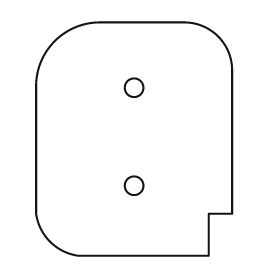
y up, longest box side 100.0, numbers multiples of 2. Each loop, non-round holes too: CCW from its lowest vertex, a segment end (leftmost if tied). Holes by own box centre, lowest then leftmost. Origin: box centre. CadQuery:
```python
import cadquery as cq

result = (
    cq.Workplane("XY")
    .moveTo(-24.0, -50.0)
    .lineTo(32.0, -50.0)
    .lineTo(32.0, -32.0)
    .lineTo(42.0, -32.0)
    .lineTo(42.0, 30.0)
    .threePointArc((36.0, 44.0), (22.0, 50.0))
    .lineTo(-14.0, 50.0)
    .threePointArc((-34.0, 42.0), (-42.0, 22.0))
    .lineTo(-42.0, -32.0)
    .threePointArc((-36.0, -44.0), (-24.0, -50.0))
    .close()
    .moveTo(0.0, -20.0)
    .circle(4.0)
    .moveTo(0.0, 22.0)
    .circle(4.0)
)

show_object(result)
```